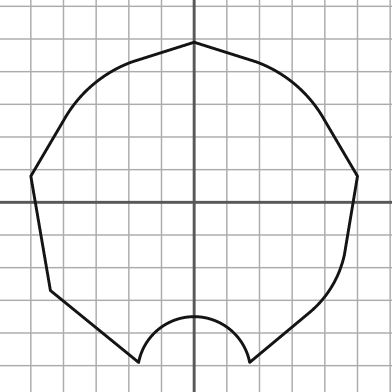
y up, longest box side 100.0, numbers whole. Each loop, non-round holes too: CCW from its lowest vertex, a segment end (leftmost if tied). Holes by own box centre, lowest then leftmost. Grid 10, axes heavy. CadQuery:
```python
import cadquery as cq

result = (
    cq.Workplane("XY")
    .moveTo(-17.0, -49.0)
    .threePointArc((0.0, -35.0), (17.0, -49.0))
    .lineTo(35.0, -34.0)
    .threePointArc((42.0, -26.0), (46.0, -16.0))
    .lineTo(50.0, 8.0)
    .lineTo(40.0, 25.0)
    .threePointArc((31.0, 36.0), (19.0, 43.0))
    .lineTo(0.0, 49.0)
    .lineTo(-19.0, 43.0)
    .threePointArc((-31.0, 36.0), (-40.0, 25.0))
    .lineTo(-50.0, 8.0)
    .lineTo(-44.0, -27.0)
    .close()
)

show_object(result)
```